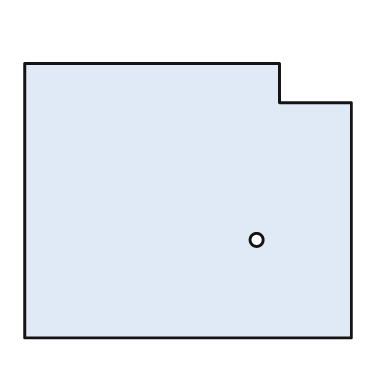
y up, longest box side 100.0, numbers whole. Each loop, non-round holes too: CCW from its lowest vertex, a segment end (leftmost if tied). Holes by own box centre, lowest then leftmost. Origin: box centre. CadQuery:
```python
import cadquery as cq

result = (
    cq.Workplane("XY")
    .moveTo(-50.0, -42.0)
    .lineTo(50.0, -42.0)
    .lineTo(50.0, 30.0)
    .lineTo(28.0, 30.0)
    .lineTo(28.0, 42.0)
    .lineTo(-50.0, 42.0)
    .close()
    .moveTo(21.0, -12.0)
    .circle(2.0)
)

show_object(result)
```